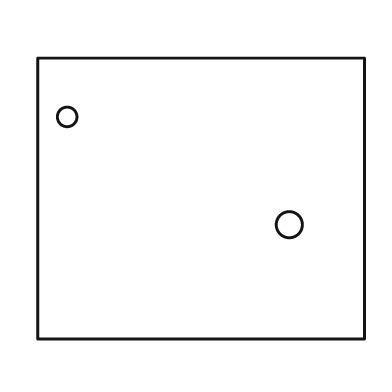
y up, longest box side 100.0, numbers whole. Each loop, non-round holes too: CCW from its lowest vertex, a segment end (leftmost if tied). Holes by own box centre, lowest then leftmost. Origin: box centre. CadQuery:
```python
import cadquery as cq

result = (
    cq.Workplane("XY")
    .moveTo(-50.0, -43.0)
    .lineTo(50.0, -43.0)
    .lineTo(50.0, 43.0)
    .lineTo(-50.0, 43.0)
    .close()
    .moveTo(27.0, -8.0)
    .circle(4.0)
    .moveTo(-41.0, 25.0)
    .circle(3.0)
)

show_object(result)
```